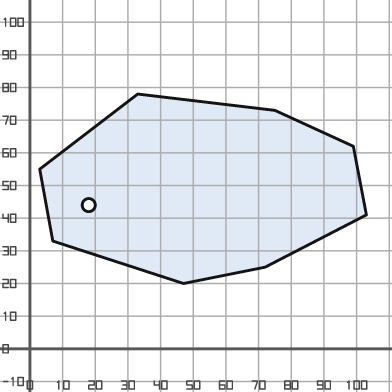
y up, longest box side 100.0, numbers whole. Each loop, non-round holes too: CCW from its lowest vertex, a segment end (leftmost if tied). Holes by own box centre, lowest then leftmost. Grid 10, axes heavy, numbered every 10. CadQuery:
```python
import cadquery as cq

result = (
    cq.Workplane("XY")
    .moveTo(47.0, 20.0)
    .lineTo(72.0, 25.0)
    .lineTo(103.0, 41.0)
    .lineTo(99.0, 62.0)
    .lineTo(75.0, 73.0)
    .lineTo(33.0, 78.0)
    .lineTo(3.0, 55.0)
    .lineTo(7.0, 33.0)
    .close()
    .moveTo(18.0, 44.0)
    .circle(2.0)
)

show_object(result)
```